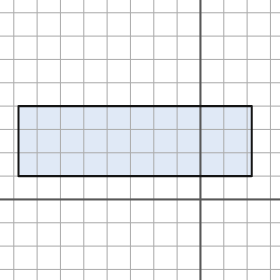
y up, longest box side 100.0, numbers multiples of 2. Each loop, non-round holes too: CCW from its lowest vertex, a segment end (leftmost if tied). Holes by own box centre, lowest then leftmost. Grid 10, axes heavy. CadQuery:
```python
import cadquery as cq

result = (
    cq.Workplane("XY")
    .moveTo(-78.0, 10.0)
    .lineTo(22.0, 10.0)
    .lineTo(22.0, 40.0)
    .lineTo(-78.0, 40.0)
    .close()
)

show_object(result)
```